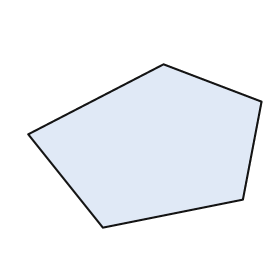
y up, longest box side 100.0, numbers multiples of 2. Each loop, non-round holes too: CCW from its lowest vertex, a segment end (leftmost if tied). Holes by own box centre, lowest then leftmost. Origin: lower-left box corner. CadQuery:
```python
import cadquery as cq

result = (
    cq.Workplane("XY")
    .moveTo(32.0, 0.0)
    .lineTo(92.0, 12.0)
    .lineTo(100.0, 54.0)
    .lineTo(58.0, 70.0)
    .lineTo(0.0, 40.0)
    .close()
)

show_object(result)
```